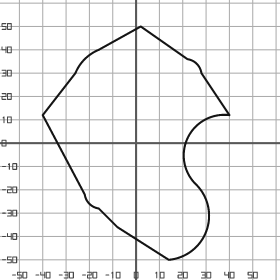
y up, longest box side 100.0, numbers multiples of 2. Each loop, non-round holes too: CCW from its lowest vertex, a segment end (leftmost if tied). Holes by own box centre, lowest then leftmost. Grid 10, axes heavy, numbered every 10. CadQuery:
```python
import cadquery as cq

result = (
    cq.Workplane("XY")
    .moveTo(14.0, -50.0)
    .threePointArc((30.0, -38.0), (26.0, -18.0))
    .threePointArc((22.0, 2.0), (40.0, 12.0))
    .lineTo(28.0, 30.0)
    .threePointArc((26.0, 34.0), (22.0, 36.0))
    .lineTo(2.0, 50.0)
    .lineTo(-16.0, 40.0)
    .threePointArc((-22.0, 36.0), (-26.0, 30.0))
    .lineTo(-40.0, 12.0)
    .lineTo(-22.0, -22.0)
    .threePointArc((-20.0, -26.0), (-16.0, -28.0))
    .lineTo(-8.0, -36.0)
    .close()
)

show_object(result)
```